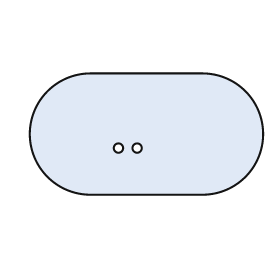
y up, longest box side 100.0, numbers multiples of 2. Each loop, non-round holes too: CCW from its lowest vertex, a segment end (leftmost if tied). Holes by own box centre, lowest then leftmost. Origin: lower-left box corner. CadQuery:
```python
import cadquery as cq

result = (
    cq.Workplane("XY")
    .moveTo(26.0, 0.0)
    .lineTo(74.0, 0.0)
    .threePointArc((100.0, 26.0), (74.0, 52.0))
    .lineTo(26.0, 52.0)
    .threePointArc((0.0, 26.0), (26.0, 0.0))
    .close()
    .moveTo(38.0, 20.0)
    .circle(2.0)
    .moveTo(46.0, 20.0)
    .circle(2.0)
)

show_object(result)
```